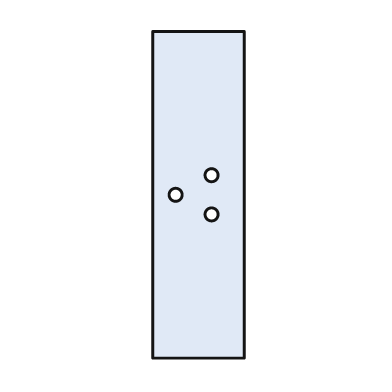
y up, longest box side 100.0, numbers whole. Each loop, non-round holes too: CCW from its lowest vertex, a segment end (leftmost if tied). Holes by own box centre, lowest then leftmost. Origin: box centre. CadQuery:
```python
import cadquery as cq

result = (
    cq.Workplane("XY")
    .moveTo(-14.0, -50.0)
    .lineTo(14.0, -50.0)
    .lineTo(14.0, 50.0)
    .lineTo(-14.0, 50.0)
    .close()
    .moveTo(4.0, -6.0)
    .circle(2.0)
    .moveTo(-7.0, 0.0)
    .circle(2.0)
    .moveTo(4.0, 6.0)
    .circle(2.0)
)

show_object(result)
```